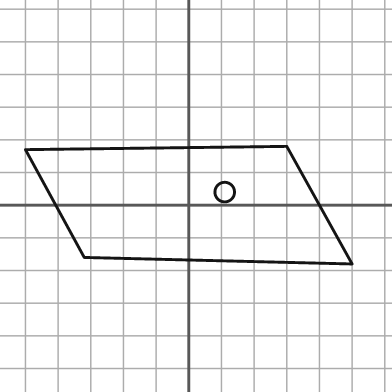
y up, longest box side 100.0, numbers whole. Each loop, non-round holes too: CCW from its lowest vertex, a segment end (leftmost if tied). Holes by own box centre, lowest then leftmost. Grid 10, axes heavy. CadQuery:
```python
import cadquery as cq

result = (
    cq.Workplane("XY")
    .moveTo(50.0, -18.0)
    .lineTo(30.0, 18.0)
    .lineTo(-50.0, 17.0)
    .lineTo(-32.0, -16.0)
    .close()
    .moveTo(11.0, 4.0)
    .circle(3.0)
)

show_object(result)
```